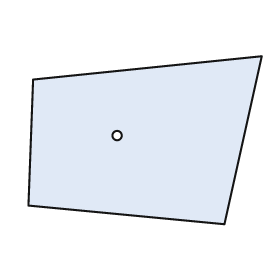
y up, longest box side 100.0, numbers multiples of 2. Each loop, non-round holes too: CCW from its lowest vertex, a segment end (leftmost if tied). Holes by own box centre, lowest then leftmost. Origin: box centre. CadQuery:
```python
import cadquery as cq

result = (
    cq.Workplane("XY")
    .moveTo(34.0, -36.0)
    .lineTo(50.0, 36.0)
    .lineTo(-48.0, 26.0)
    .lineTo(-50.0, -28.0)
    .close()
    .moveTo(-12.0, 2.0)
    .circle(2.0)
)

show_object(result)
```